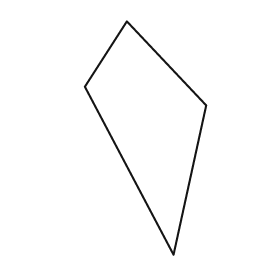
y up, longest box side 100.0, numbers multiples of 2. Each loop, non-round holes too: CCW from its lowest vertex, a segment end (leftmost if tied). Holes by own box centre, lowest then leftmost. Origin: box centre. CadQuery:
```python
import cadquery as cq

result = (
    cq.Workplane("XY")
    .moveTo(12.0, -50.0)
    .lineTo(26.0, 14.0)
    .lineTo(-8.0, 50.0)
    .lineTo(-26.0, 22.0)
    .close()
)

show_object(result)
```